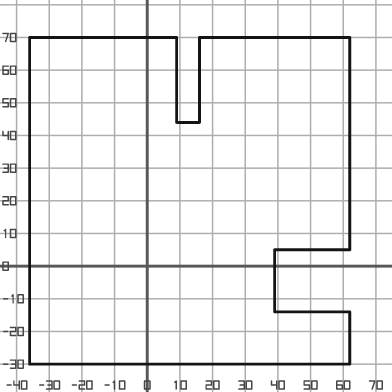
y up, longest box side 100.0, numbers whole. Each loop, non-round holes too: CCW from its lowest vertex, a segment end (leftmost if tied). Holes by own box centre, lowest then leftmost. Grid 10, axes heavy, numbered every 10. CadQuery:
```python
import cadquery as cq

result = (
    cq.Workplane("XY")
    .moveTo(-36.0, -30.0)
    .lineTo(62.0, -30.0)
    .lineTo(62.0, -14.0)
    .lineTo(39.0, -14.0)
    .lineTo(39.0, 5.0)
    .lineTo(62.0, 5.0)
    .lineTo(62.0, 70.0)
    .lineTo(16.0, 70.0)
    .lineTo(16.0, 44.0)
    .lineTo(9.0, 44.0)
    .lineTo(9.0, 70.0)
    .lineTo(-36.0, 70.0)
    .close()
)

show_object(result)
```